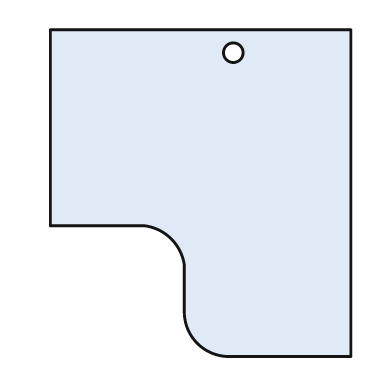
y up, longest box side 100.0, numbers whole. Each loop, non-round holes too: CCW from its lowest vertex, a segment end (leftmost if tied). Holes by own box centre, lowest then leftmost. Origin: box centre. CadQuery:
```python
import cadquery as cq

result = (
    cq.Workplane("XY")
    .moveTo(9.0, -50.0)
    .lineTo(46.0, -50.0)
    .lineTo(46.0, 50.0)
    .lineTo(-46.0, 50.0)
    .lineTo(-46.0, -10.0)
    .lineTo(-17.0, -10.0)
    .threePointArc((-9.0, -14.0), (-5.0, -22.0))
    .lineTo(-5.0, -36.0)
    .threePointArc((-1.0, -46.0), (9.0, -50.0))
    .close()
    .moveTo(10.0, 43.0)
    .circle(3.0)
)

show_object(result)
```